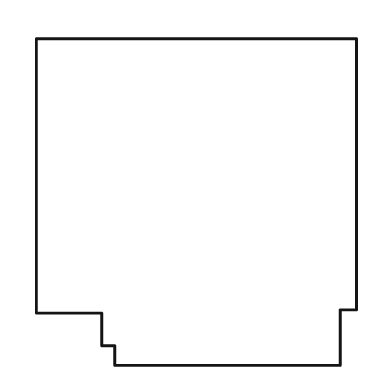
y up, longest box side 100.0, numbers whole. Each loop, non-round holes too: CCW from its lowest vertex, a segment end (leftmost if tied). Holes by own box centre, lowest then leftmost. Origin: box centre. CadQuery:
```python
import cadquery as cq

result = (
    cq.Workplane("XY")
    .moveTo(-25.0, -50.0)
    .lineTo(44.0, -50.0)
    .lineTo(44.0, -33.0)
    .lineTo(49.0, -33.0)
    .lineTo(49.0, 50.0)
    .lineTo(-49.0, 50.0)
    .lineTo(-49.0, -34.0)
    .lineTo(-29.0, -34.0)
    .lineTo(-29.0, -44.0)
    .lineTo(-25.0, -44.0)
    .close()
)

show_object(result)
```